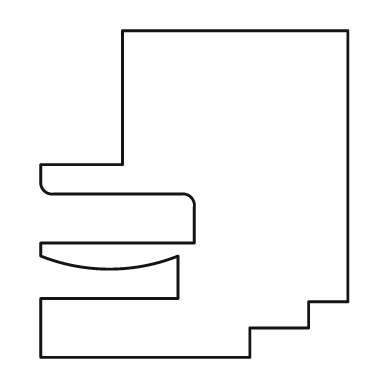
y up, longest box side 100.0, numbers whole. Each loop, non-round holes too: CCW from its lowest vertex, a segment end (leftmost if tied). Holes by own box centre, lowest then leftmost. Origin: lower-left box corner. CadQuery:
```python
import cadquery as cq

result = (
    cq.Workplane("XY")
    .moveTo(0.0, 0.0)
    .lineTo(64.0, 0.0)
    .lineTo(64.0, 9.0)
    .lineTo(82.0, 9.0)
    .lineTo(82.0, 17.0)
    .lineTo(94.0, 17.0)
    .lineTo(94.0, 100.0)
    .lineTo(25.0, 100.0)
    .lineTo(25.0, 59.0)
    .lineTo(0.0, 59.0)
    .lineTo(0.0, 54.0)
    .threePointArc((1.0, 51.0), (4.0, 50.0))
    .lineTo(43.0, 50.0)
    .threePointArc((46.0, 49.0), (47.0, 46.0))
    .lineTo(47.0, 35.0)
    .lineTo(0.0, 35.0)
    .lineTo(0.0, 31.0)
    .threePointArc((21.0, 27.0), (42.0, 31.0))
    .lineTo(42.0, 18.0)
    .lineTo(0.0, 18.0)
    .close()
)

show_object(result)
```